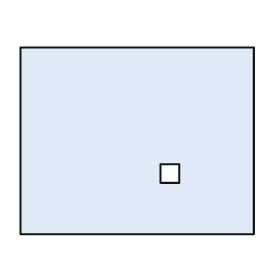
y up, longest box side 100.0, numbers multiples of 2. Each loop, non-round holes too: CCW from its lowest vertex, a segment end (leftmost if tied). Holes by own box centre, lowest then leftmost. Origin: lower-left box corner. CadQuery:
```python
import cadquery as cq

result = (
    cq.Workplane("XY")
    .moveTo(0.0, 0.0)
    .lineTo(100.0, 0.0)
    .lineTo(100.0, 80.0)
    .lineTo(0.0, 80.0)
    .close()
    .moveTo(60.0, 22.0)
    .lineTo(68.0, 22.0)
    .lineTo(68.0, 30.0)
    .lineTo(60.0, 30.0)
    .close()
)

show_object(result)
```